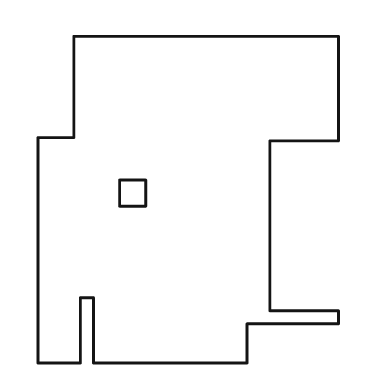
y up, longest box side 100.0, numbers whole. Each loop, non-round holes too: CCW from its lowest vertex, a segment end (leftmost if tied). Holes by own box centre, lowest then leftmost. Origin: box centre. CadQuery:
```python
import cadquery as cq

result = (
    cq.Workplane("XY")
    .moveTo(-46.0, -50.0)
    .lineTo(-33.0, -50.0)
    .lineTo(-33.0, -30.0)
    .lineTo(-29.0, -30.0)
    .lineTo(-29.0, -50.0)
    .lineTo(18.0, -50.0)
    .lineTo(18.0, -38.0)
    .lineTo(46.0, -38.0)
    .lineTo(46.0, -34.0)
    .lineTo(25.0, -34.0)
    .lineTo(25.0, 18.0)
    .lineTo(46.0, 18.0)
    .lineTo(46.0, 50.0)
    .lineTo(-35.0, 50.0)
    .lineTo(-35.0, 19.0)
    .lineTo(-46.0, 19.0)
    .close()
    .moveTo(-21.0, -2.0)
    .lineTo(-13.0, -2.0)
    .lineTo(-13.0, 6.0)
    .lineTo(-21.0, 6.0)
    .close()
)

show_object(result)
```